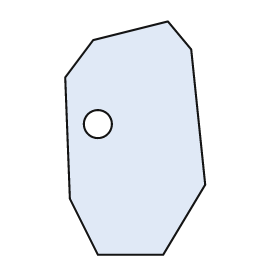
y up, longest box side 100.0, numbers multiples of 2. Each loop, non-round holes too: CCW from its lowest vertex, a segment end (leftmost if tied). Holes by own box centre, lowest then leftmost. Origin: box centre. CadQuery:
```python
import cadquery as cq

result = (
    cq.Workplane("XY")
    .moveTo(-16.0, -50.0)
    .lineTo(12.0, -50.0)
    .lineTo(30.0, -20.0)
    .lineTo(24.0, 38.0)
    .lineTo(14.0, 50.0)
    .lineTo(-18.0, 42.0)
    .lineTo(-30.0, 26.0)
    .lineTo(-28.0, -26.0)
    .close()
    .moveTo(-16.0, 6.0)
    .circle(6.0)
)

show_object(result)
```